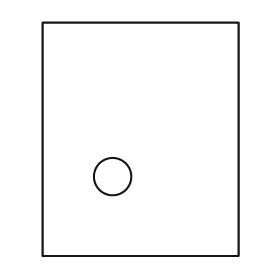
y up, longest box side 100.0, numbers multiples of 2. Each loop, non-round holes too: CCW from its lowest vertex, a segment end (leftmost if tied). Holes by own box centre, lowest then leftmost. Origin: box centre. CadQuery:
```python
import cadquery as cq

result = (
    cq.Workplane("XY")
    .moveTo(-42.0, -50.0)
    .lineTo(42.0, -50.0)
    .lineTo(42.0, 50.0)
    .lineTo(-42.0, 50.0)
    .close()
    .moveTo(-12.0, -16.0)
    .circle(8.0)
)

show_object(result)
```